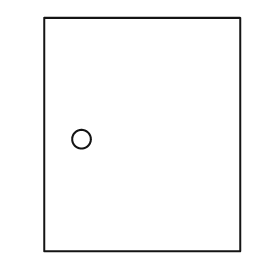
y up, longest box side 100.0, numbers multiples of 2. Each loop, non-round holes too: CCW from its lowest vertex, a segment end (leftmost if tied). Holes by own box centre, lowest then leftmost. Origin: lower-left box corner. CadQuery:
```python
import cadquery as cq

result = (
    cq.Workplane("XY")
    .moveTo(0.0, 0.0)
    .lineTo(84.0, 0.0)
    .lineTo(84.0, 100.0)
    .lineTo(0.0, 100.0)
    .close()
    .moveTo(16.0, 48.0)
    .circle(4.0)
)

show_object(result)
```